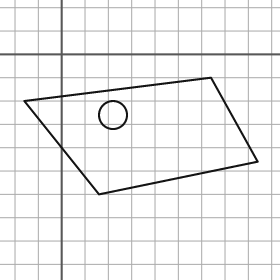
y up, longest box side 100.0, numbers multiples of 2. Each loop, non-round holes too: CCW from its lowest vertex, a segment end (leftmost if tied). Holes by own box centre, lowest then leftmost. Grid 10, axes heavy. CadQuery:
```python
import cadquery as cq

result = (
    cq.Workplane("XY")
    .moveTo(16.0, -60.0)
    .lineTo(84.0, -46.0)
    .lineTo(64.0, -10.0)
    .lineTo(-16.0, -20.0)
    .close()
    .moveTo(22.0, -26.0)
    .circle(6.0)
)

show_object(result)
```